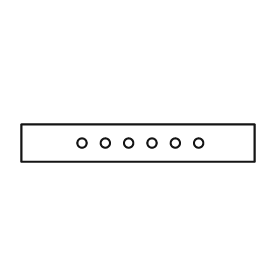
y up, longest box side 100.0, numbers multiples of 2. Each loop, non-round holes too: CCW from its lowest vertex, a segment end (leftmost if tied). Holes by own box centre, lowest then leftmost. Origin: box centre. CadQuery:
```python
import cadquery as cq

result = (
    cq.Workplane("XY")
    .moveTo(-50.0, -8.0)
    .lineTo(50.0, -8.0)
    .lineTo(50.0, 8.0)
    .lineTo(-50.0, 8.0)
    .close()
    .moveTo(-24.0, 0.0)
    .circle(2.0)
    .moveTo(-14.0, 0.0)
    .circle(2.0)
    .moveTo(-4.0, 0.0)
    .circle(2.0)
    .moveTo(6.0, 0.0)
    .circle(2.0)
    .moveTo(16.0, 0.0)
    .circle(2.0)
    .moveTo(26.0, 0.0)
    .circle(2.0)
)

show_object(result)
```